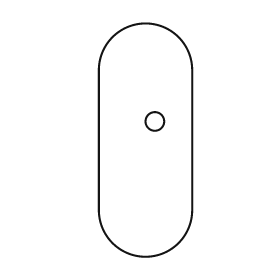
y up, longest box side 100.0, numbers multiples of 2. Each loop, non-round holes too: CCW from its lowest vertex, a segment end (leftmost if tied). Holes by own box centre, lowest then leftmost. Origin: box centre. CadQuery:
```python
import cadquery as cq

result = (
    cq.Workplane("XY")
    .moveTo(-20.0, -30.0)
    .threePointArc((0.0, -50.0), (20.0, -30.0))
    .lineTo(20.0, 30.0)
    .threePointArc((0.0, 50.0), (-20.0, 30.0))
    .close()
    .moveTo(4.0, 8.0)
    .circle(4.0)
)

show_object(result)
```